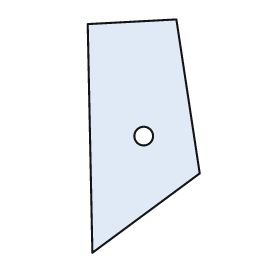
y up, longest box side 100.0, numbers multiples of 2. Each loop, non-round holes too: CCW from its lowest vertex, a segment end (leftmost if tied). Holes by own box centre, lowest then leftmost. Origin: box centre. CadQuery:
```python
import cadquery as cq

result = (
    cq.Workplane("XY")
    .moveTo(-22.0, -50.0)
    .lineTo(24.0, -16.0)
    .lineTo(14.0, 50.0)
    .lineTo(-24.0, 48.0)
    .close()
    .moveTo(0.0, 0.0)
    .circle(4.0)
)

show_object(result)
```